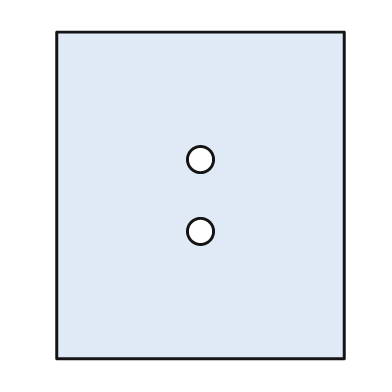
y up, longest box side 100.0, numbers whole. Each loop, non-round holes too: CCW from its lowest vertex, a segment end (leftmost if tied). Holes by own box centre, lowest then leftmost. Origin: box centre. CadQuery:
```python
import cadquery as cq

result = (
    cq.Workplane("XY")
    .moveTo(-44.0, -50.0)
    .lineTo(44.0, -50.0)
    .lineTo(44.0, 50.0)
    .lineTo(-44.0, 50.0)
    .close()
    .moveTo(0.0, -11.0)
    .circle(4.0)
    .moveTo(0.0, 11.0)
    .circle(4.0)
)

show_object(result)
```